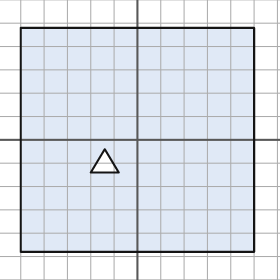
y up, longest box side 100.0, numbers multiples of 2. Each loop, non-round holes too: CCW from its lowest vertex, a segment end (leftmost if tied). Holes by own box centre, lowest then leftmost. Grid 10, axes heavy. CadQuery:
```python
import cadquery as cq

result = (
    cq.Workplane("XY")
    .moveTo(-50.0, -48.0)
    .lineTo(50.0, -48.0)
    .lineTo(50.0, 48.0)
    .lineTo(-50.0, 48.0)
    .close()
    .moveTo(-20.0, -14.0)
    .lineTo(-8.0, -14.0)
    .lineTo(-14.0, -4.0)
    .close()
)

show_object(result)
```